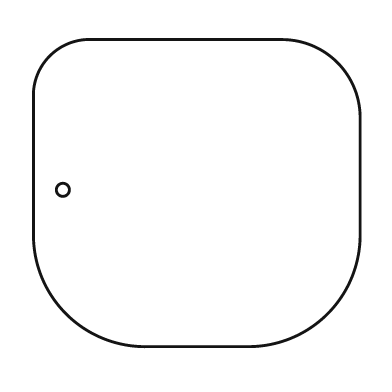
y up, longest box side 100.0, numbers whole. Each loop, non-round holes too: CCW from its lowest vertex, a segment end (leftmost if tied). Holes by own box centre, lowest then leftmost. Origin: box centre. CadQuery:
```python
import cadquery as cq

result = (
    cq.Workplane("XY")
    .moveTo(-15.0, -47.0)
    .lineTo(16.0, -47.0)
    .threePointArc((40.0, -37.0), (50.0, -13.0))
    .lineTo(50.0, 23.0)
    .threePointArc((43.0, 40.0), (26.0, 47.0))
    .lineTo(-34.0, 47.0)
    .threePointArc((-45.0, 42.0), (-50.0, 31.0))
    .lineTo(-50.0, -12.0)
    .threePointArc((-40.0, -37.0), (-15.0, -47.0))
    .close()
    .moveTo(-41.0, 1.0)
    .circle(2.0)
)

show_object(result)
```